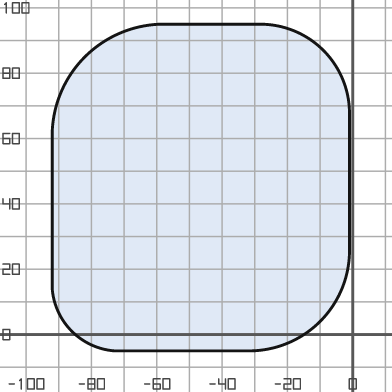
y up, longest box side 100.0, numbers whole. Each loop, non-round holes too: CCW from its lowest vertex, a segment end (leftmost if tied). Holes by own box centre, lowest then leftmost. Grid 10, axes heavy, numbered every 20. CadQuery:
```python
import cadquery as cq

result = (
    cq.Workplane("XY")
    .moveTo(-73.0, -5.0)
    .lineTo(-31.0, -5.0)
    .threePointArc((-10.0, 4.0), (-1.0, 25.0))
    .lineTo(-1.0, 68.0)
    .threePointArc((-9.0, 87.0), (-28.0, 95.0))
    .lineTo(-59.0, 95.0)
    .threePointArc((-82.0, 85.0), (-92.0, 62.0))
    .lineTo(-92.0, 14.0)
    .threePointArc((-86.0, 1.0), (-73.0, -5.0))
    .close()
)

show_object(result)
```